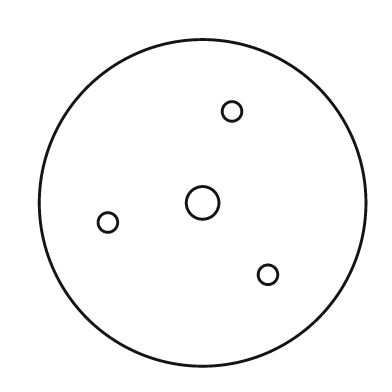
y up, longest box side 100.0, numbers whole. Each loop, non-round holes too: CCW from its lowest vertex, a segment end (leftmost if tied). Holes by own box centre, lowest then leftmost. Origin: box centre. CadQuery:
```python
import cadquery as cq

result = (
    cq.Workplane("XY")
    .moveTo(0.0, 0.0)
    .circle(50.0)
    .moveTo(20.0, -22.0)
    .circle(3.0)
    .moveTo(-29.0, -6.0)
    .circle(3.0)
    .moveTo(0.0, 0.0)
    .circle(5.0)
    .moveTo(9.0, 28.0)
    .circle(3.0)
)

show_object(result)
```